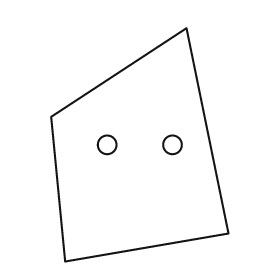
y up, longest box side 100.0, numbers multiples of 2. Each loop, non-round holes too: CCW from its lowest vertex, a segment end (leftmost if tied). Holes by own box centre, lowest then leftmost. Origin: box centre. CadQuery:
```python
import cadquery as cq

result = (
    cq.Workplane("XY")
    .moveTo(-32.0, -50.0)
    .lineTo(38.0, -38.0)
    .lineTo(20.0, 50.0)
    .lineTo(-38.0, 12.0)
    .close()
    .moveTo(-14.0, 0.0)
    .circle(4.0)
    .moveTo(14.0, 0.0)
    .circle(4.0)
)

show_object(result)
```